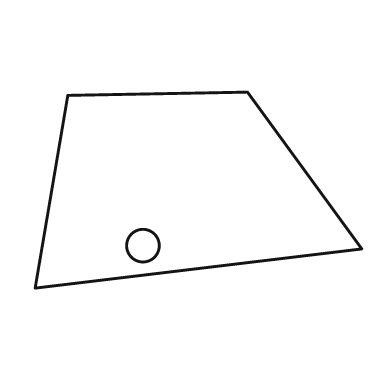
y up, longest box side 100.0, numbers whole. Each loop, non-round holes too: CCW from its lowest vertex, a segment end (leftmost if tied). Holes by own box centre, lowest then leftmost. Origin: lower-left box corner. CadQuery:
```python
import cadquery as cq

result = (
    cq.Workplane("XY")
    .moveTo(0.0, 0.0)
    .lineTo(100.0, 12.0)
    .lineTo(65.0, 60.0)
    .lineTo(10.0, 59.0)
    .close()
    .moveTo(33.0, 13.0)
    .circle(5.0)
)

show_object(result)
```